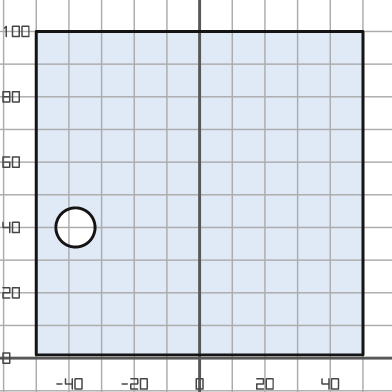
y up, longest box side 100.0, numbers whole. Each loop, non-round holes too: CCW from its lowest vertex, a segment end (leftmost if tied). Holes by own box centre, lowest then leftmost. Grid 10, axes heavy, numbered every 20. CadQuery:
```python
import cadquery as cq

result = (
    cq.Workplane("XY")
    .moveTo(-50.0, 1.0)
    .lineTo(50.0, 1.0)
    .lineTo(50.0, 100.0)
    .lineTo(-50.0, 100.0)
    .close()
    .moveTo(-38.0, 40.0)
    .circle(6.0)
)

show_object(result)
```